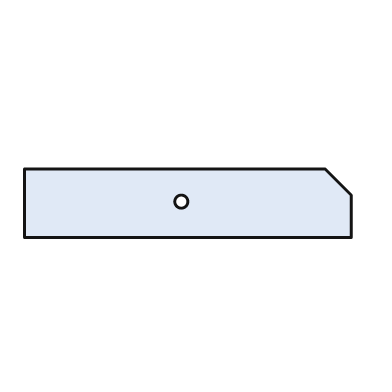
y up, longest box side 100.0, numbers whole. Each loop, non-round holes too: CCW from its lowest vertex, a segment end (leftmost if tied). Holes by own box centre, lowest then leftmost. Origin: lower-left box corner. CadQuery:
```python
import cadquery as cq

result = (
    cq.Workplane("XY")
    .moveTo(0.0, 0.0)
    .lineTo(100.0, 0.0)
    .lineTo(100.0, 13.0)
    .lineTo(92.0, 21.0)
    .lineTo(0.0, 21.0)
    .close()
    .moveTo(48.0, 11.0)
    .circle(2.0)
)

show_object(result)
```